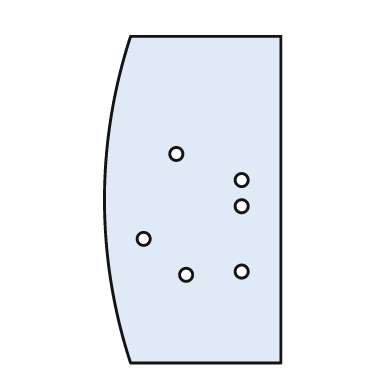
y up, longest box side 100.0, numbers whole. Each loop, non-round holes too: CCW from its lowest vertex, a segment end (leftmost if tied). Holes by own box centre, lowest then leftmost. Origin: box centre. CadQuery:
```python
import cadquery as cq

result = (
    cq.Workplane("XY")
    .moveTo(-19.0, -50.0)
    .lineTo(27.0, -50.0)
    .lineTo(27.0, 50.0)
    .lineTo(-19.0, 50.0)
    .threePointArc((-27.0, 0.0), (-19.0, -50.0))
    .close()
    .moveTo(-2.0, -23.0)
    .circle(2.0)
    .moveTo(15.0, -22.0)
    .circle(2.0)
    .moveTo(-15.0, -12.0)
    .circle(2.0)
    .moveTo(15.0, -2.0)
    .circle(2.0)
    .moveTo(15.0, 6.0)
    .circle(2.0)
    .moveTo(-5.0, 14.0)
    .circle(2.0)
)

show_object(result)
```